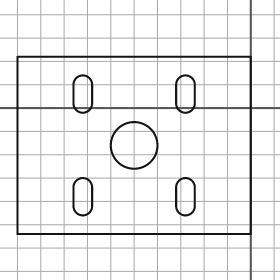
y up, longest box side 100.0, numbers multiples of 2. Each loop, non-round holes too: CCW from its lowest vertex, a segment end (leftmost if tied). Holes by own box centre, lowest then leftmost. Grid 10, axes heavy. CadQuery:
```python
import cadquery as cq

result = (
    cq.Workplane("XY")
    .moveTo(-100.0, -54.0)
    .lineTo(0.0, -54.0)
    .lineTo(0.0, 22.0)
    .lineTo(-100.0, 22.0)
    .close()
    .moveTo(-76.0, -42.0)
    .threePointArc((-72.0, -46.0), (-68.0, -42.0))
    .lineTo(-68.0, -34.0)
    .threePointArc((-72.0, -30.0), (-76.0, -34.0))
    .close()
    .moveTo(-32.0, -42.0)
    .threePointArc((-28.0, -46.0), (-24.0, -42.0))
    .lineTo(-24.0, -34.0)
    .threePointArc((-28.0, -30.0), (-32.0, -34.0))
    .close()
    .moveTo(-50.0, -16.0)
    .circle(10.0)
    .moveTo(-76.0, 2.0)
    .threePointArc((-72.0, -2.0), (-68.0, 2.0))
    .lineTo(-68.0, 10.0)
    .threePointArc((-72.0, 14.0), (-76.0, 10.0))
    .close()
    .moveTo(-32.0, 2.0)
    .threePointArc((-28.0, -2.0), (-24.0, 2.0))
    .lineTo(-24.0, 10.0)
    .threePointArc((-28.0, 14.0), (-32.0, 10.0))
    .close()
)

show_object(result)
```